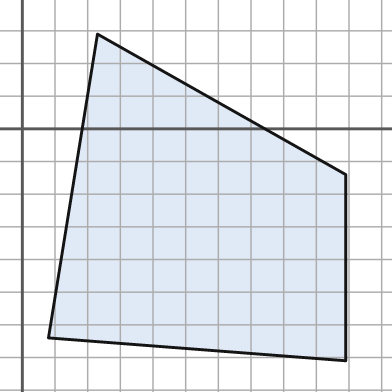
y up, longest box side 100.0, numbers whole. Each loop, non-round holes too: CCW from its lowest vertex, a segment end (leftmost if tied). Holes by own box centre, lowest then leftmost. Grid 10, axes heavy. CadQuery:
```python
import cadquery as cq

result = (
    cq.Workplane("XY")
    .moveTo(99.0, -71.0)
    .lineTo(99.0, -14.0)
    .lineTo(23.0, 29.0)
    .lineTo(8.0, -64.0)
    .close()
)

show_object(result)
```